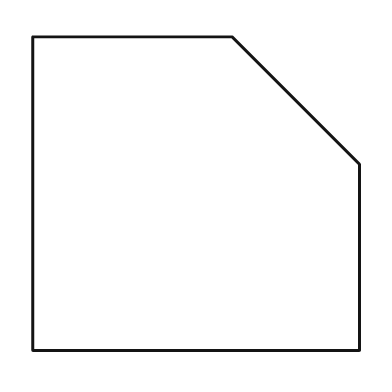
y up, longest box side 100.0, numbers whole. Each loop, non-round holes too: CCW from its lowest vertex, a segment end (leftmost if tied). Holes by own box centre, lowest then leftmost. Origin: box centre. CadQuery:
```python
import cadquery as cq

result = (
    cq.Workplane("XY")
    .moveTo(-50.0, -48.0)
    .lineTo(50.0, -48.0)
    .lineTo(50.0, 9.0)
    .lineTo(11.0, 48.0)
    .lineTo(-50.0, 48.0)
    .close()
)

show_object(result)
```